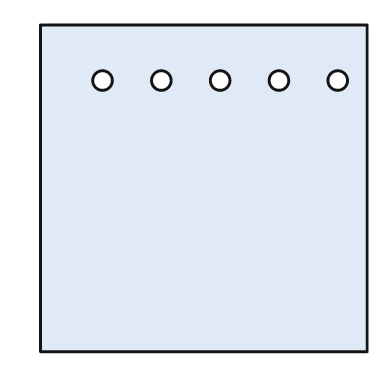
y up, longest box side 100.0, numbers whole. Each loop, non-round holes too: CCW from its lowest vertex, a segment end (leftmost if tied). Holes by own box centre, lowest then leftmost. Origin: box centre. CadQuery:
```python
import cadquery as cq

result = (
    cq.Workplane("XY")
    .moveTo(-50.0, -50.0)
    .lineTo(50.0, -50.0)
    .lineTo(50.0, 50.0)
    .lineTo(-50.0, 50.0)
    .close()
    .moveTo(-31.0, 33.0)
    .circle(3.0)
    .moveTo(-13.0, 33.0)
    .circle(3.0)
    .moveTo(5.0, 33.0)
    .circle(3.0)
    .moveTo(23.0, 33.0)
    .circle(3.0)
    .moveTo(41.0, 33.0)
    .circle(3.0)
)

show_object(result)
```